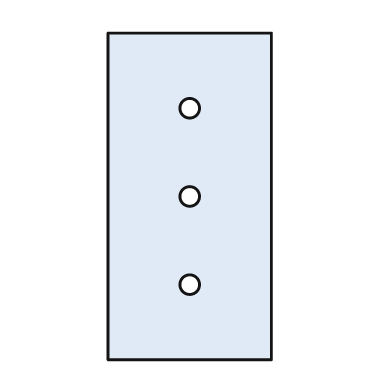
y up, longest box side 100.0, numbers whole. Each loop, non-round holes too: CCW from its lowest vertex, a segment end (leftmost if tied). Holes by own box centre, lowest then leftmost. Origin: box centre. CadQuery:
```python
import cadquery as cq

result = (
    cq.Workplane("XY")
    .moveTo(-25.0, -50.0)
    .lineTo(25.0, -50.0)
    .lineTo(25.0, 50.0)
    .lineTo(-25.0, 50.0)
    .close()
    .moveTo(0.0, -27.0)
    .circle(3.0)
    .moveTo(0.0, 0.0)
    .circle(3.0)
    .moveTo(0.0, 27.0)
    .circle(3.0)
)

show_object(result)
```